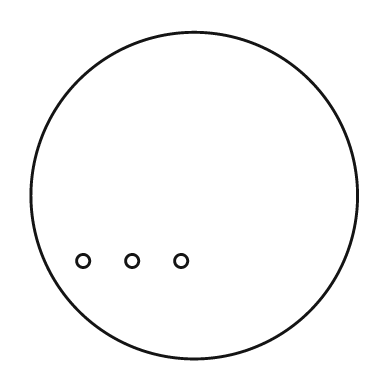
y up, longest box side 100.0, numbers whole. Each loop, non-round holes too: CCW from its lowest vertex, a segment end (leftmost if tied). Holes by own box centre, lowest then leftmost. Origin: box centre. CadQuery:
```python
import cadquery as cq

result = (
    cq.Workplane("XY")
    .moveTo(0.0, 0.0)
    .circle(50.0)
    .moveTo(-34.0, -20.0)
    .circle(2.0)
    .moveTo(-19.0, -20.0)
    .circle(2.0)
    .moveTo(-4.0, -20.0)
    .circle(2.0)
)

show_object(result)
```